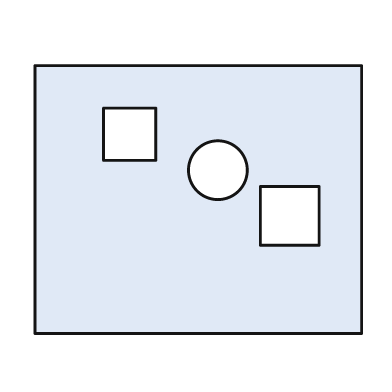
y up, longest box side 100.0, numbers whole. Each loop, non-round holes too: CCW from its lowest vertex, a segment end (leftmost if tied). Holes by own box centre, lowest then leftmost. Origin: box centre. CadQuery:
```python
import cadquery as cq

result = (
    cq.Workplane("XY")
    .moveTo(-50.0, -41.0)
    .lineTo(50.0, -41.0)
    .lineTo(50.0, 41.0)
    .lineTo(-50.0, 41.0)
    .close()
    .moveTo(19.0, -14.0)
    .lineTo(37.0, -14.0)
    .lineTo(37.0, 4.0)
    .lineTo(19.0, 4.0)
    .close()
    .moveTo(6.0, 9.0)
    .circle(9.0)
    .moveTo(-29.0, 12.0)
    .lineTo(-13.0, 12.0)
    .lineTo(-13.0, 28.0)
    .lineTo(-29.0, 28.0)
    .close()
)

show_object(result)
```